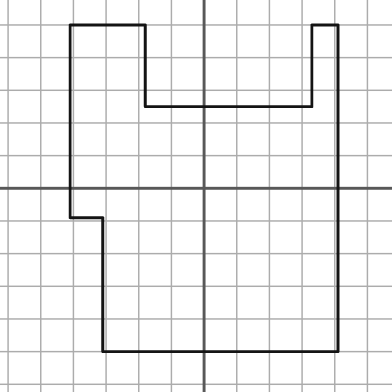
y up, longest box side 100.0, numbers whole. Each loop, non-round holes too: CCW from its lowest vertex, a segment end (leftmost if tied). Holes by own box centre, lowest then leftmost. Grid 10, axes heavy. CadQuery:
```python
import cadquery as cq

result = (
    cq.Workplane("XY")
    .moveTo(-31.0, -50.0)
    .lineTo(41.0, -50.0)
    .lineTo(41.0, 50.0)
    .lineTo(33.0, 50.0)
    .lineTo(33.0, 25.0)
    .lineTo(-18.0, 25.0)
    .lineTo(-18.0, 50.0)
    .lineTo(-41.0, 50.0)
    .lineTo(-41.0, -9.0)
    .lineTo(-31.0, -9.0)
    .close()
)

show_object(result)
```